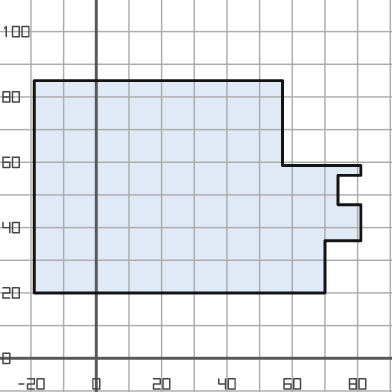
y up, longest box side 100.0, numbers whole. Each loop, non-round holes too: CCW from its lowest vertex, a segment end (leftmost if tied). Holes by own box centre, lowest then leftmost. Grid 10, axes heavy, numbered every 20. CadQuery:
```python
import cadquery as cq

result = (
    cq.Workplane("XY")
    .moveTo(-19.0, 20.0)
    .lineTo(70.0, 20.0)
    .lineTo(70.0, 36.0)
    .lineTo(81.0, 36.0)
    .lineTo(81.0, 47.0)
    .lineTo(74.0, 47.0)
    .lineTo(74.0, 56.0)
    .lineTo(81.0, 56.0)
    .lineTo(81.0, 59.0)
    .lineTo(57.0, 59.0)
    .lineTo(57.0, 85.0)
    .lineTo(-19.0, 85.0)
    .close()
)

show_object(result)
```